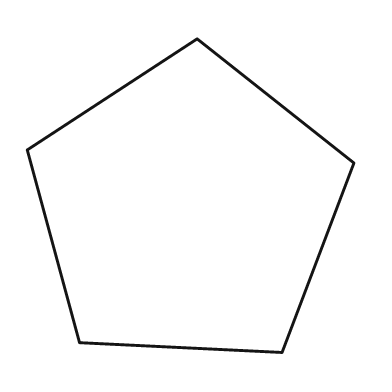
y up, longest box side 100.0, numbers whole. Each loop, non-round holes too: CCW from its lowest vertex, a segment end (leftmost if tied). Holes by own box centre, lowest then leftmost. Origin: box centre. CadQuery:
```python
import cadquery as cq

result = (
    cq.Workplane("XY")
    .moveTo(28.0, -48.0)
    .lineTo(50.0, 10.0)
    .lineTo(2.0, 48.0)
    .lineTo(-50.0, 14.0)
    .lineTo(-34.0, -45.0)
    .close()
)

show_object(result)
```